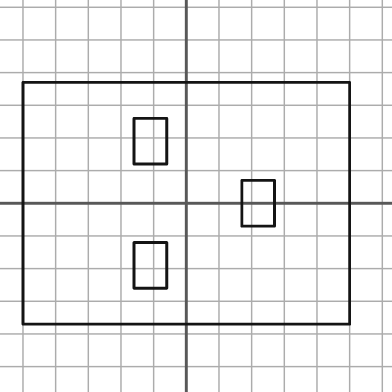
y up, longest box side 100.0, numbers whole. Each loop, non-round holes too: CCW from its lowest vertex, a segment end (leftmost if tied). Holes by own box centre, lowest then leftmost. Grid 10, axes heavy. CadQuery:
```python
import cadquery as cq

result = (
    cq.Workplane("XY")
    .moveTo(-50.0, -37.0)
    .lineTo(50.0, -37.0)
    .lineTo(50.0, 37.0)
    .lineTo(-50.0, 37.0)
    .close()
    .moveTo(-16.0, -26.0)
    .lineTo(-6.0, -26.0)
    .lineTo(-6.0, -12.0)
    .lineTo(-16.0, -12.0)
    .close()
    .moveTo(17.0, -7.0)
    .lineTo(27.0, -7.0)
    .lineTo(27.0, 7.0)
    .lineTo(17.0, 7.0)
    .close()
    .moveTo(-16.0, 12.0)
    .lineTo(-6.0, 12.0)
    .lineTo(-6.0, 26.0)
    .lineTo(-16.0, 26.0)
    .close()
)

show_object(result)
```